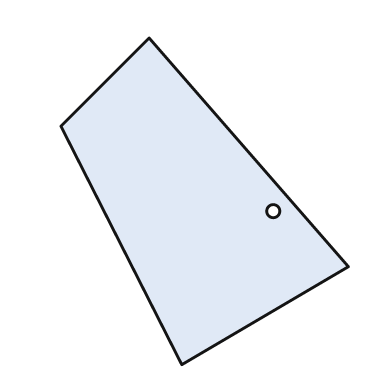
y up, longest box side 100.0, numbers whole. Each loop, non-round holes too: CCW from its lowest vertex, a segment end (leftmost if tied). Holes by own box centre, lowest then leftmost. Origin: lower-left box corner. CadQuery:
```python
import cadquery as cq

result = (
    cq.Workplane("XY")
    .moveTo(37.0, 0.0)
    .lineTo(88.0, 30.0)
    .lineTo(27.0, 100.0)
    .lineTo(0.0, 73.0)
    .close()
    .moveTo(65.0, 47.0)
    .circle(2.0)
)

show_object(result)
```